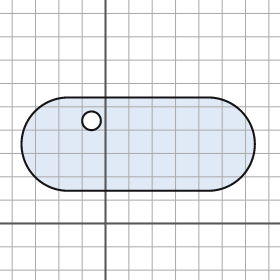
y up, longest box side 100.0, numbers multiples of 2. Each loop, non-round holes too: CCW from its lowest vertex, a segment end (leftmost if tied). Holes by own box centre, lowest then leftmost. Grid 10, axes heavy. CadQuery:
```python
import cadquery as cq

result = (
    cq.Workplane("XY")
    .moveTo(-16.0, 14.0)
    .lineTo(44.0, 14.0)
    .threePointArc((64.0, 34.0), (44.0, 54.0))
    .lineTo(-16.0, 54.0)
    .threePointArc((-36.0, 34.0), (-16.0, 14.0))
    .close()
    .moveTo(-6.0, 44.0)
    .circle(4.0)
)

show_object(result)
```